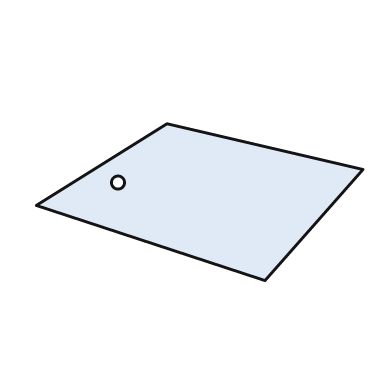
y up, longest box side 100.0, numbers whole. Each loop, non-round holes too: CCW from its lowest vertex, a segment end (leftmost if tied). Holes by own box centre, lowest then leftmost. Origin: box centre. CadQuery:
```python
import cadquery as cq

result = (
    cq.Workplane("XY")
    .moveTo(20.0, -24.0)
    .lineTo(50.0, 10.0)
    .lineTo(-10.0, 24.0)
    .lineTo(-50.0, -1.0)
    .close()
    .moveTo(-25.0, 6.0)
    .circle(2.0)
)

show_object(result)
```